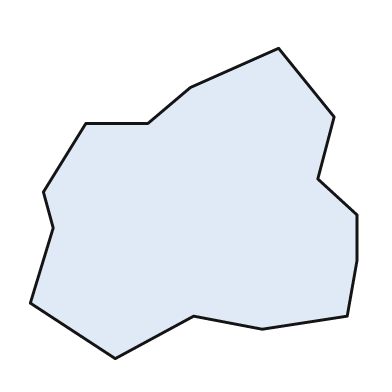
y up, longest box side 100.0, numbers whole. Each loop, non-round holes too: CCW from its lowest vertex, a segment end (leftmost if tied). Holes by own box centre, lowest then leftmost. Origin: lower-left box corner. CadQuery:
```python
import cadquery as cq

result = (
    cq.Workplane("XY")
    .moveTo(26.0, 0.0)
    .lineTo(50.0, 13.0)
    .lineTo(71.0, 9.0)
    .lineTo(97.0, 13.0)
    .lineTo(100.0, 30.0)
    .lineTo(100.0, 44.0)
    .lineTo(88.0, 55.0)
    .lineTo(93.0, 74.0)
    .lineTo(76.0, 95.0)
    .lineTo(49.0, 83.0)
    .lineTo(36.0, 72.0)
    .lineTo(17.0, 72.0)
    .lineTo(4.0, 51.0)
    .lineTo(7.0, 40.0)
    .lineTo(0.0, 17.0)
    .close()
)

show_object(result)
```